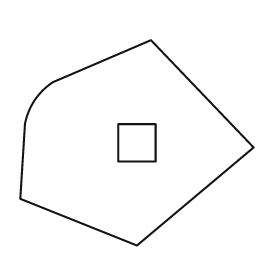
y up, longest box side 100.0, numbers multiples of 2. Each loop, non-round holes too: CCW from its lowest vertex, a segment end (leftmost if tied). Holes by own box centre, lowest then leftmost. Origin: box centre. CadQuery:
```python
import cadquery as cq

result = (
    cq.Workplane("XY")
    .moveTo(0.0, -44.0)
    .lineTo(50.0, -2.0)
    .lineTo(6.0, 44.0)
    .lineTo(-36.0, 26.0)
    .threePointArc((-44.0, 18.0), (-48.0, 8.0))
    .lineTo(-50.0, -24.0)
    .close()
    .moveTo(-8.0, -8.0)
    .lineTo(8.0, -8.0)
    .lineTo(8.0, 8.0)
    .lineTo(-8.0, 8.0)
    .close()
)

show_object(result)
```